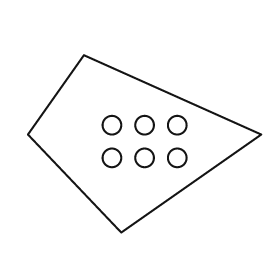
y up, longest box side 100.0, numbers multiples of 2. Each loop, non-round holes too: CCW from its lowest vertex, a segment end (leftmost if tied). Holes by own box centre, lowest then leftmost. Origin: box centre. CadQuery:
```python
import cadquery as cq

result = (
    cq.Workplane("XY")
    .moveTo(-10.0, -38.0)
    .lineTo(50.0, 4.0)
    .lineTo(-26.0, 38.0)
    .lineTo(-50.0, 4.0)
    .close()
    .moveTo(-14.0, -6.0)
    .circle(4.0)
    .moveTo(0.0, -6.0)
    .circle(4.0)
    .moveTo(14.0, -6.0)
    .circle(4.0)
    .moveTo(-14.0, 8.0)
    .circle(4.0)
    .moveTo(0.0, 8.0)
    .circle(4.0)
    .moveTo(14.0, 8.0)
    .circle(4.0)
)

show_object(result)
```